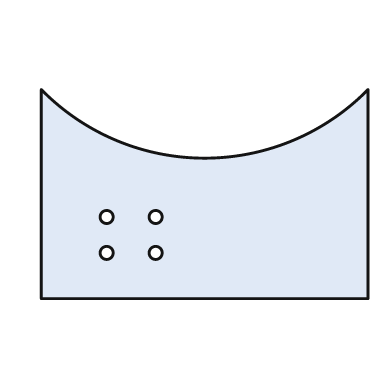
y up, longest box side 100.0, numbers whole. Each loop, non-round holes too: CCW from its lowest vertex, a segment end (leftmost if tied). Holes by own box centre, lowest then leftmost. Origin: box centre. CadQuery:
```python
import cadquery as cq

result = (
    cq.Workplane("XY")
    .moveTo(-50.0, -32.0)
    .lineTo(50.0, -32.0)
    .lineTo(50.0, 32.0)
    .threePointArc((0.0, 11.0), (-50.0, 32.0))
    .close()
    .moveTo(-30.0, -18.0)
    .circle(2.0)
    .moveTo(-15.0, -18.0)
    .circle(2.0)
    .moveTo(-30.0, -7.0)
    .circle(2.0)
    .moveTo(-15.0, -7.0)
    .circle(2.0)
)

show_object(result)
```